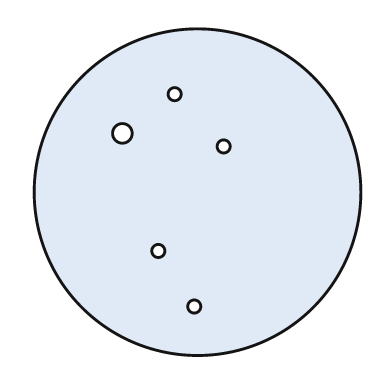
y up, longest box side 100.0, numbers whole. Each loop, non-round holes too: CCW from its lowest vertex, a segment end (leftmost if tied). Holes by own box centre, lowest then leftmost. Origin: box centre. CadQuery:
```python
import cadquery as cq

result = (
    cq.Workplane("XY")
    .moveTo(0.0, 0.0)
    .circle(50.0)
    .moveTo(-1.0, -35.0)
    .circle(2.0)
    .moveTo(-12.0, -18.0)
    .circle(2.0)
    .moveTo(8.0, 14.0)
    .circle(2.0)
    .moveTo(-23.0, 18.0)
    .circle(3.0)
    .moveTo(-7.0, 30.0)
    .circle(2.0)
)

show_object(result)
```